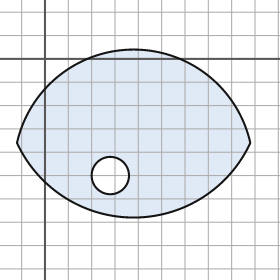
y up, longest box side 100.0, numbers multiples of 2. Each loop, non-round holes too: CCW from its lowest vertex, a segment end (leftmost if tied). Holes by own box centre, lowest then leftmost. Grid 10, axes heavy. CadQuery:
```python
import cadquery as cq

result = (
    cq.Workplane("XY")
    .moveTo(-12.0, -36.0)
    .threePointArc((38.0, -68.0), (88.0, -36.0))
    .threePointArc((38.0, 4.0), (-12.0, -36.0))
    .close()
    .moveTo(28.0, -50.0)
    .circle(8.0)
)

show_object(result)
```